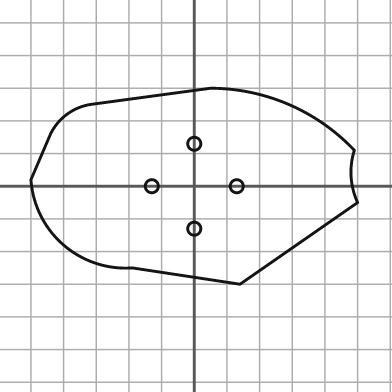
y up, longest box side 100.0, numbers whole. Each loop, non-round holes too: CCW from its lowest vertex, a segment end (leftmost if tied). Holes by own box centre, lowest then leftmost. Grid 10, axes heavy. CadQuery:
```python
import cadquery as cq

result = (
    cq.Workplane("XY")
    .moveTo(14.0, -30.0)
    .lineTo(50.0, -5.0)
    .threePointArc((48.0, 3.0), (49.0, 11.0))
    .threePointArc((29.0, 25.0), (5.0, 30.0))
    .lineTo(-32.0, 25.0)
    .threePointArc((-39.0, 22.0), (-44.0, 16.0))
    .lineTo(-50.0, 2.0)
    .threePointArc((-40.0, -18.0), (-19.0, -25.0))
    .close()
    .moveTo(0.0, -13.0)
    .circle(2.0)
    .moveTo(-13.0, 0.0)
    .circle(2.0)
    .moveTo(13.0, 0.0)
    .circle(2.0)
    .moveTo(0.0, 13.0)
    .circle(2.0)
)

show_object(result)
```